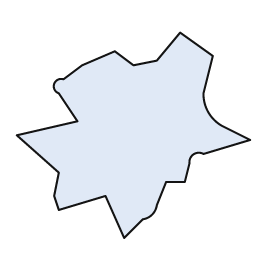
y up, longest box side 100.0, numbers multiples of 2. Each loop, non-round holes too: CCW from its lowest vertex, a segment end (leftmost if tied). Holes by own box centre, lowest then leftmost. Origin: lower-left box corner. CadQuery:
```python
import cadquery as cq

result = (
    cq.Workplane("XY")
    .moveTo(46.0, 0.0)
    .lineTo(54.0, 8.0)
    .threePointArc((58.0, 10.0), (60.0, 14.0))
    .lineTo(64.0, 24.0)
    .lineTo(72.0, 24.0)
    .lineTo(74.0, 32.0)
    .threePointArc((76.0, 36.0), (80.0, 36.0))
    .lineTo(100.0, 42.0)
    .lineTo(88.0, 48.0)
    .threePointArc((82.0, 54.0), (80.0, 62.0))
    .lineTo(84.0, 78.0)
    .lineTo(70.0, 88.0)
    .lineTo(60.0, 76.0)
    .lineTo(50.0, 74.0)
    .lineTo(42.0, 80.0)
    .lineTo(28.0, 74.0)
    .lineTo(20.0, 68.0)
    .threePointArc((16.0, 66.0), (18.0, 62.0))
    .lineTo(26.0, 50.0)
    .lineTo(0.0, 44.0)
    .lineTo(18.0, 28.0)
    .lineTo(16.0, 18.0)
    .lineTo(18.0, 12.0)
    .lineTo(38.0, 18.0)
    .close()
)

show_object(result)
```